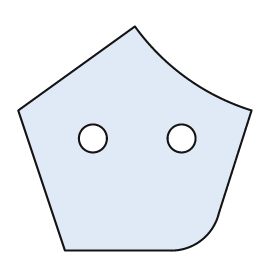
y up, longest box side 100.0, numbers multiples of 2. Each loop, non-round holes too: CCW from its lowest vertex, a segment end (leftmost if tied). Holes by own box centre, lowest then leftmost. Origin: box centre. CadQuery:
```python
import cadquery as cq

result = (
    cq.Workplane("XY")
    .moveTo(-30.0, -48.0)
    .lineTo(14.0, -48.0)
    .threePointArc((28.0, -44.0), (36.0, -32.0))
    .lineTo(50.0, 12.0)
    .threePointArc((22.0, 26.0), (0.0, 48.0))
    .lineTo(-50.0, 12.0)
    .close()
    .moveTo(-18.0, 0.0)
    .circle(6.0)
    .moveTo(20.0, 0.0)
    .circle(6.0)
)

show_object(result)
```